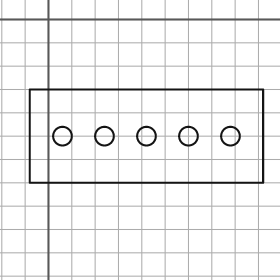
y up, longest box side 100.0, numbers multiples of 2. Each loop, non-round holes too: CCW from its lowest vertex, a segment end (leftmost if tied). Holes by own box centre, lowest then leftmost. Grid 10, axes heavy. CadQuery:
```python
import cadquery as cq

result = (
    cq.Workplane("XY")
    .moveTo(-8.0, -70.0)
    .lineTo(92.0, -70.0)
    .lineTo(92.0, -30.0)
    .lineTo(-8.0, -30.0)
    .close()
    .moveTo(6.0, -50.0)
    .circle(4.0)
    .moveTo(24.0, -50.0)
    .circle(4.0)
    .moveTo(42.0, -50.0)
    .circle(4.0)
    .moveTo(60.0, -50.0)
    .circle(4.0)
    .moveTo(78.0, -50.0)
    .circle(4.0)
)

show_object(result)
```